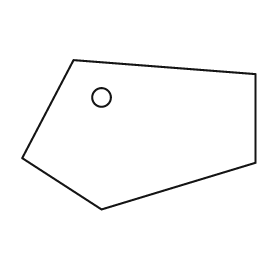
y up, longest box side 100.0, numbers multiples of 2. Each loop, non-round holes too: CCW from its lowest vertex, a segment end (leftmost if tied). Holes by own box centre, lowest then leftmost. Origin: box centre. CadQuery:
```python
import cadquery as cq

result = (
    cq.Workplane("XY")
    .moveTo(-16.0, -32.0)
    .lineTo(50.0, -12.0)
    .lineTo(50.0, 26.0)
    .lineTo(-28.0, 32.0)
    .lineTo(-50.0, -10.0)
    .close()
    .moveTo(-16.0, 16.0)
    .circle(4.0)
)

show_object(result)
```